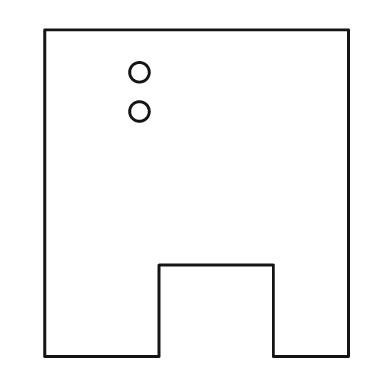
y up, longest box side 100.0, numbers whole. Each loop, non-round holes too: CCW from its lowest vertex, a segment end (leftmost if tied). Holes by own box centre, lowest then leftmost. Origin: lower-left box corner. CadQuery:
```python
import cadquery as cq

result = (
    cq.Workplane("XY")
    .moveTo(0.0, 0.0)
    .lineTo(35.0, 0.0)
    .lineTo(35.0, 28.0)
    .lineTo(70.0, 28.0)
    .lineTo(70.0, 0.0)
    .lineTo(93.0, 0.0)
    .lineTo(93.0, 100.0)
    .lineTo(0.0, 100.0)
    .close()
    .moveTo(29.0, 75.0)
    .circle(3.0)
    .moveTo(29.0, 87.0)
    .circle(3.0)
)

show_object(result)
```